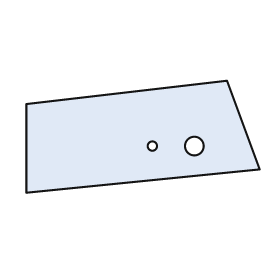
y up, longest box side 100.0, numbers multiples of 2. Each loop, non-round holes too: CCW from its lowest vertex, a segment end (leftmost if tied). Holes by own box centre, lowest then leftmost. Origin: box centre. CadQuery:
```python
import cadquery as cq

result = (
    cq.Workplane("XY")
    .moveTo(-50.0, -24.0)
    .lineTo(50.0, -14.0)
    .lineTo(36.0, 24.0)
    .lineTo(-50.0, 14.0)
    .close()
    .moveTo(4.0, -4.0)
    .circle(2.0)
    .moveTo(22.0, -4.0)
    .circle(4.0)
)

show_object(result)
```